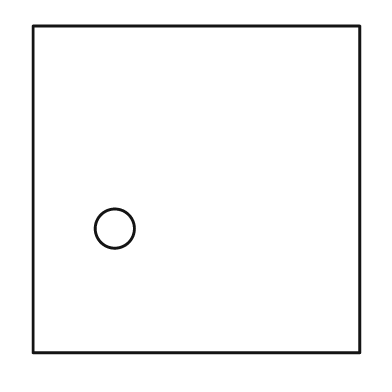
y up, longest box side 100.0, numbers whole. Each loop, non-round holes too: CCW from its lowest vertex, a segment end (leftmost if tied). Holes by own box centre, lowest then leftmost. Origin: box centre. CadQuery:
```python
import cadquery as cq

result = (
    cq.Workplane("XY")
    .moveTo(-50.0, -50.0)
    .lineTo(50.0, -50.0)
    .lineTo(50.0, 50.0)
    .lineTo(-50.0, 50.0)
    .close()
    .moveTo(-25.0, -12.0)
    .circle(6.0)
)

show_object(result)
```